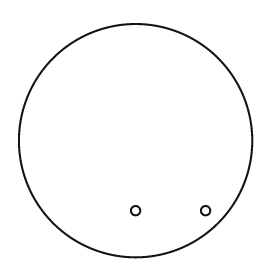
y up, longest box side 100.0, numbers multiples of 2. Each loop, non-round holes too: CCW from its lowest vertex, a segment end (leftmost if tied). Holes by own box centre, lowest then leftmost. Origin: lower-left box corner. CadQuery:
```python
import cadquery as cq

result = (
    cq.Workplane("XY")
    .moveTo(50.0, 50.0)
    .circle(50.0)
    .moveTo(50.0, 20.0)
    .circle(2.0)
    .moveTo(80.0, 20.0)
    .circle(2.0)
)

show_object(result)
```